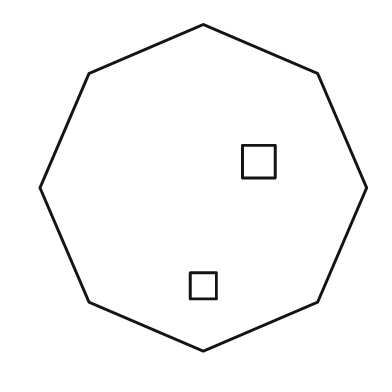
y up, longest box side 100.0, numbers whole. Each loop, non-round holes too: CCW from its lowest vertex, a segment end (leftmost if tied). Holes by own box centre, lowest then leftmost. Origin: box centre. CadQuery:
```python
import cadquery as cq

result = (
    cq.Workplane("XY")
    .moveTo(0.0, -50.0)
    .lineTo(35.0, -35.0)
    .lineTo(50.0, 0.0)
    .lineTo(35.0, 35.0)
    .lineTo(0.0, 50.0)
    .lineTo(-35.0, 35.0)
    .lineTo(-50.0, 0.0)
    .lineTo(-35.0, -35.0)
    .close()
    .moveTo(-4.0, -34.0)
    .lineTo(4.0, -34.0)
    .lineTo(4.0, -26.0)
    .lineTo(-4.0, -26.0)
    .close()
    .moveTo(12.0, 3.0)
    .lineTo(22.0, 3.0)
    .lineTo(22.0, 13.0)
    .lineTo(12.0, 13.0)
    .close()
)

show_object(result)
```